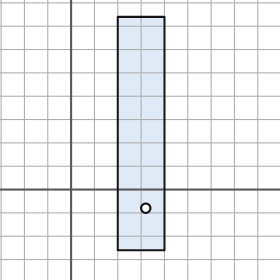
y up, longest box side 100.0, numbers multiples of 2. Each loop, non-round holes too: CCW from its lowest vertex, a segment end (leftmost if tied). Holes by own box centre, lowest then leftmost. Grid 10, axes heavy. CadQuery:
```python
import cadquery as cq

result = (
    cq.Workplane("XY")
    .moveTo(20.0, -26.0)
    .lineTo(40.0, -26.0)
    .lineTo(40.0, 74.0)
    .lineTo(20.0, 74.0)
    .close()
    .moveTo(32.0, -8.0)
    .circle(2.0)
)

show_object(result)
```